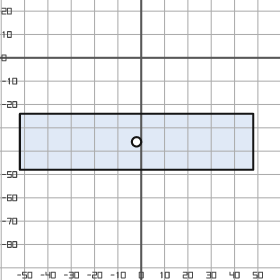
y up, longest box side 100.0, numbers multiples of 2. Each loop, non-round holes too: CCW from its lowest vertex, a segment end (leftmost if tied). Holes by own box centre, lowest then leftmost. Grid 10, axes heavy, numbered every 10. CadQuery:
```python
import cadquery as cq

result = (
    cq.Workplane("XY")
    .moveTo(-52.0, -48.0)
    .lineTo(48.0, -48.0)
    .lineTo(48.0, -24.0)
    .lineTo(-52.0, -24.0)
    .close()
    .moveTo(-2.0, -36.0)
    .circle(2.0)
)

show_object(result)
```